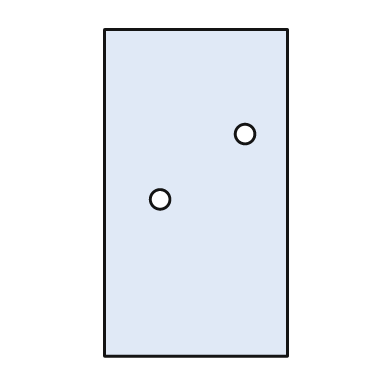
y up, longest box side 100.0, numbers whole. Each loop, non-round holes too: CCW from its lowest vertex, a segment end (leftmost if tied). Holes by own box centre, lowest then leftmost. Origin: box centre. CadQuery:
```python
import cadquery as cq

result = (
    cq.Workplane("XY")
    .moveTo(-28.0, -50.0)
    .lineTo(28.0, -50.0)
    .lineTo(28.0, 50.0)
    .lineTo(-28.0, 50.0)
    .close()
    .moveTo(-11.0, -2.0)
    .circle(3.0)
    .moveTo(15.0, 18.0)
    .circle(3.0)
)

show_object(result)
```